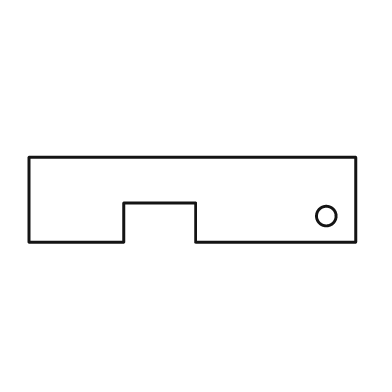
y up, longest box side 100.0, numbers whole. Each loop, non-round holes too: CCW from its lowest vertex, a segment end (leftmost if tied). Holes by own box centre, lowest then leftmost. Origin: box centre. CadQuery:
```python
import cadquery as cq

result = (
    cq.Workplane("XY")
    .moveTo(-50.0, -13.0)
    .lineTo(-21.0, -13.0)
    .lineTo(-21.0, -1.0)
    .lineTo(1.0, -1.0)
    .lineTo(1.0, -13.0)
    .lineTo(50.0, -13.0)
    .lineTo(50.0, 13.0)
    .lineTo(-50.0, 13.0)
    .close()
    .moveTo(41.0, -5.0)
    .circle(3.0)
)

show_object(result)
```